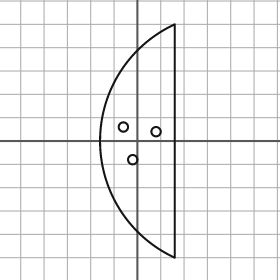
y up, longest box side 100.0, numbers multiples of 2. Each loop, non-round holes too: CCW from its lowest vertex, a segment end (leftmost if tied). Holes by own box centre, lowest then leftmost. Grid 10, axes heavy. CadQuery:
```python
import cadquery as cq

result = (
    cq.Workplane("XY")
    .moveTo(16.0, -50.0)
    .lineTo(16.0, 50.0)
    .threePointArc((-16.0, 0.0), (16.0, -50.0))
    .close()
    .moveTo(-2.0, -8.0)
    .circle(2.0)
    .moveTo(8.0, 4.0)
    .circle(2.0)
    .moveTo(-6.0, 6.0)
    .circle(2.0)
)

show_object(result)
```